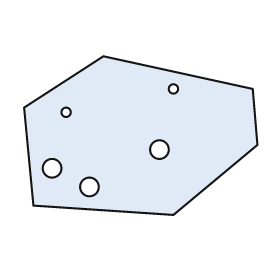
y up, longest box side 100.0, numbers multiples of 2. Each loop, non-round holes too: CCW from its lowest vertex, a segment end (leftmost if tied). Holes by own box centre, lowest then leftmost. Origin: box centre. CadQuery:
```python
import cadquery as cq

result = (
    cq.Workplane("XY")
    .moveTo(14.0, -34.0)
    .lineTo(50.0, -4.0)
    .lineTo(48.0, 20.0)
    .lineTo(-16.0, 34.0)
    .lineTo(-50.0, 12.0)
    .lineTo(-46.0, -30.0)
    .close()
    .moveTo(-22.0, -22.0)
    .circle(4.0)
    .moveTo(-38.0, -14.0)
    .circle(4.0)
    .moveTo(8.0, -6.0)
    .circle(4.0)
    .moveTo(-32.0, 10.0)
    .circle(2.0)
    .moveTo(14.0, 20.0)
    .circle(2.0)
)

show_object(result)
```